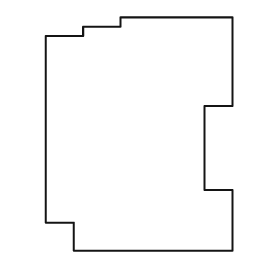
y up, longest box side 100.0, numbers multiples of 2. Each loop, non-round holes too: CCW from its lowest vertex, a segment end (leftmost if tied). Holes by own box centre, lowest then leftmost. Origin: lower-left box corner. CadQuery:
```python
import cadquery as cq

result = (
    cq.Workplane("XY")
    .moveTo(12.0, 0.0)
    .lineTo(80.0, 0.0)
    .lineTo(80.0, 26.0)
    .lineTo(68.0, 26.0)
    .lineTo(68.0, 62.0)
    .lineTo(80.0, 62.0)
    .lineTo(80.0, 100.0)
    .lineTo(32.0, 100.0)
    .lineTo(32.0, 96.0)
    .lineTo(16.0, 96.0)
    .lineTo(16.0, 92.0)
    .lineTo(0.0, 92.0)
    .lineTo(0.0, 12.0)
    .lineTo(12.0, 12.0)
    .close()
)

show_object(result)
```